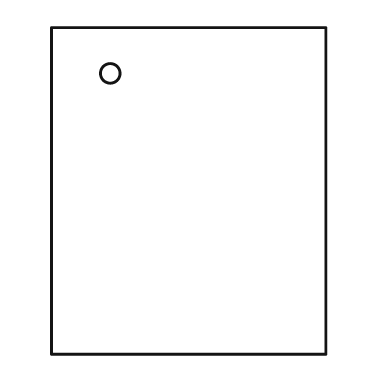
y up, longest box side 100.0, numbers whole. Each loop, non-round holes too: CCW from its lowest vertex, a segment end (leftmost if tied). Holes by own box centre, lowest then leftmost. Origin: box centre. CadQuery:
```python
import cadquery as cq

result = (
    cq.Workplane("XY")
    .moveTo(-42.0, -50.0)
    .lineTo(42.0, -50.0)
    .lineTo(42.0, 50.0)
    .lineTo(-42.0, 50.0)
    .close()
    .moveTo(-24.0, 36.0)
    .circle(3.0)
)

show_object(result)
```